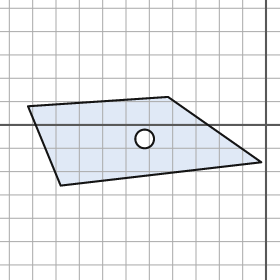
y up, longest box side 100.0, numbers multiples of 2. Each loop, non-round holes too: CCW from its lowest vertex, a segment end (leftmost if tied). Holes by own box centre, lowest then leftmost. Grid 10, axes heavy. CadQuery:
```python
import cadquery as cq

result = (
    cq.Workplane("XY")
    .moveTo(-88.0, -26.0)
    .lineTo(-2.0, -16.0)
    .lineTo(-42.0, 12.0)
    .lineTo(-102.0, 8.0)
    .close()
    .moveTo(-52.0, -6.0)
    .circle(4.0)
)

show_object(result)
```